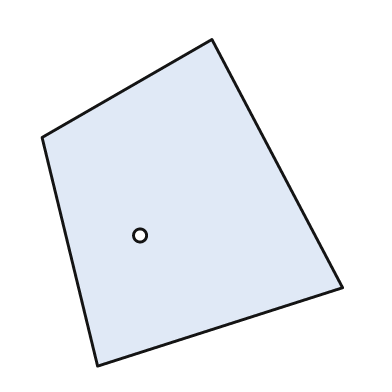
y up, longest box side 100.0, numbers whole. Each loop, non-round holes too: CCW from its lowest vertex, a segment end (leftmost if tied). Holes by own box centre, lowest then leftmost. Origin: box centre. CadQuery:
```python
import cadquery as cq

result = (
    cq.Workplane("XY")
    .moveTo(-29.0, -50.0)
    .lineTo(46.0, -26.0)
    .lineTo(6.0, 50.0)
    .lineTo(-46.0, 20.0)
    .close()
    .moveTo(-16.0, -10.0)
    .circle(2.0)
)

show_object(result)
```